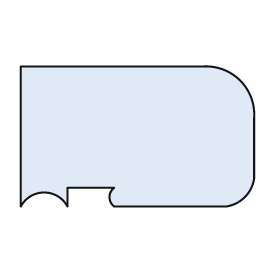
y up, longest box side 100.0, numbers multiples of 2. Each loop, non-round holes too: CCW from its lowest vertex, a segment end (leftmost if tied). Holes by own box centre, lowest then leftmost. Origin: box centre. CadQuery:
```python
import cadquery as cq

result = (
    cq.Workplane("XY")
    .moveTo(-50.0, -30.0)
    .threePointArc((-40.0, -24.0), (-30.0, -30.0))
    .lineTo(-30.0, -22.0)
    .lineTo(-10.0, -22.0)
    .threePointArc((-12.0, -26.0), (-10.0, -30.0))
    .lineTo(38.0, -30.0)
    .threePointArc((46.0, -26.0), (50.0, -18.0))
    .lineTo(50.0, 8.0)
    .threePointArc((44.0, 24.0), (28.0, 30.0))
    .lineTo(-50.0, 30.0)
    .close()
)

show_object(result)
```